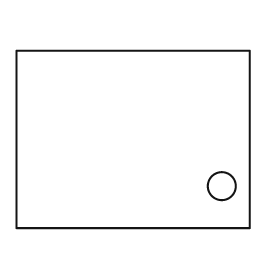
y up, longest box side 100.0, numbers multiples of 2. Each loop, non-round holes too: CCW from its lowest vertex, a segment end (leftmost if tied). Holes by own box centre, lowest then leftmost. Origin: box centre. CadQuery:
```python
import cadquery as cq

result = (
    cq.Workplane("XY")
    .moveTo(-50.0, -38.0)
    .lineTo(50.0, -38.0)
    .lineTo(50.0, 38.0)
    .lineTo(-50.0, 38.0)
    .close()
    .moveTo(38.0, -20.0)
    .circle(6.0)
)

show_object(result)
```